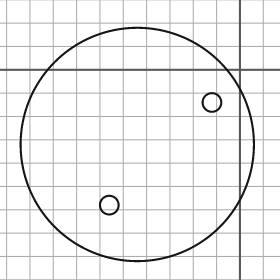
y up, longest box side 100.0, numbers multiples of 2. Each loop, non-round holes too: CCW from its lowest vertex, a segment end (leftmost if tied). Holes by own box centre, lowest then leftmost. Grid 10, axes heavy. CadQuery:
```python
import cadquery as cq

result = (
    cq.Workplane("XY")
    .moveTo(-44.0, -32.0)
    .circle(50.0)
    .moveTo(-56.0, -58.0)
    .circle(4.0)
    .moveTo(-12.0, -14.0)
    .circle(4.0)
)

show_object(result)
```